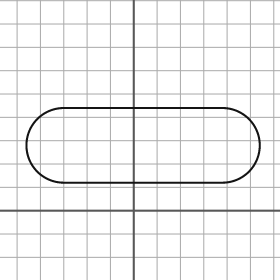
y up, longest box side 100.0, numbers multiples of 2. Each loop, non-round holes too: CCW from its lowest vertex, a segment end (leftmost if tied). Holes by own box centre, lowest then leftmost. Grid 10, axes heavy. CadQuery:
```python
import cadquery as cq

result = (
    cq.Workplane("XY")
    .moveTo(-30.0, 12.0)
    .lineTo(38.0, 12.0)
    .threePointArc((54.0, 28.0), (38.0, 44.0))
    .lineTo(-30.0, 44.0)
    .threePointArc((-46.0, 28.0), (-30.0, 12.0))
    .close()
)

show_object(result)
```